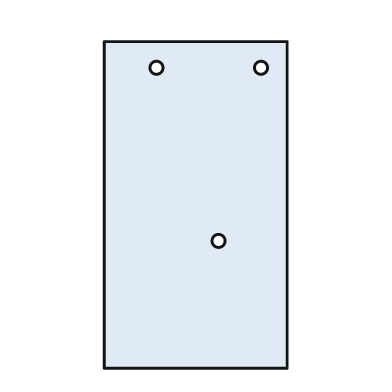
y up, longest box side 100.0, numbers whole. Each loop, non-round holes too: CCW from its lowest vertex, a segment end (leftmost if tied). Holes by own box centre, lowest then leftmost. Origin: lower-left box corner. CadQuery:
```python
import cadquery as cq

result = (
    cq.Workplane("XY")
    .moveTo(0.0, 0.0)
    .lineTo(56.0, 0.0)
    .lineTo(56.0, 100.0)
    .lineTo(0.0, 100.0)
    .close()
    .moveTo(35.0, 39.0)
    .circle(2.0)
    .moveTo(16.0, 92.0)
    .circle(2.0)
    .moveTo(48.0, 92.0)
    .circle(2.0)
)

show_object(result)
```